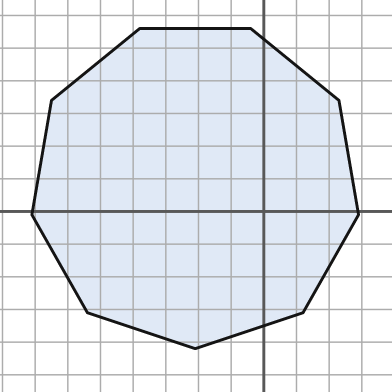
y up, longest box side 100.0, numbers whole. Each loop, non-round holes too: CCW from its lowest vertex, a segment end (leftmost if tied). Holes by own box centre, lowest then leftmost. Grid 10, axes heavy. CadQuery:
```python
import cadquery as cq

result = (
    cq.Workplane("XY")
    .moveTo(-21.0, -42.0)
    .lineTo(12.0, -31.0)
    .lineTo(29.0, -1.0)
    .lineTo(23.0, 34.0)
    .lineTo(-4.0, 56.0)
    .lineTo(-38.0, 56.0)
    .lineTo(-65.0, 34.0)
    .lineTo(-71.0, -1.0)
    .lineTo(-54.0, -31.0)
    .close()
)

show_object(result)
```